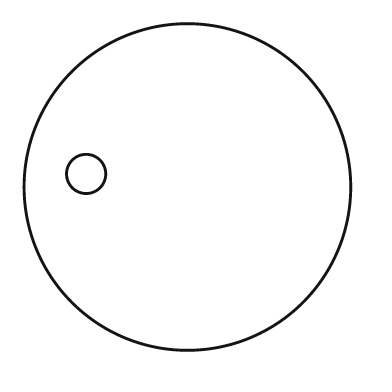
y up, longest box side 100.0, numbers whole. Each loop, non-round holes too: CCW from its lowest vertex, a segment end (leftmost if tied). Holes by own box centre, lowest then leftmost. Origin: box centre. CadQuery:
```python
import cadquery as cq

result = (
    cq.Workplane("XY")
    .moveTo(0.0, 0.0)
    .circle(50.0)
    .moveTo(-31.0, 4.0)
    .circle(6.0)
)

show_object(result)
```